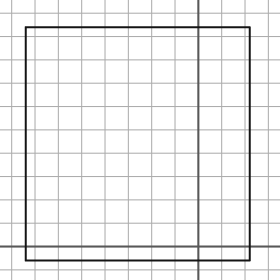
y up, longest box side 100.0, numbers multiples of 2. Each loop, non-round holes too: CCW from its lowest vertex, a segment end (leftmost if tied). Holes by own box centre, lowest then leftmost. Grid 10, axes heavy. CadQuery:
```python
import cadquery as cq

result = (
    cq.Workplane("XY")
    .moveTo(-74.0, -6.0)
    .lineTo(22.0, -6.0)
    .lineTo(22.0, 94.0)
    .lineTo(-74.0, 94.0)
    .close()
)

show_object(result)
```